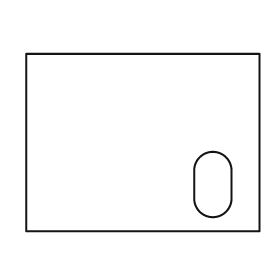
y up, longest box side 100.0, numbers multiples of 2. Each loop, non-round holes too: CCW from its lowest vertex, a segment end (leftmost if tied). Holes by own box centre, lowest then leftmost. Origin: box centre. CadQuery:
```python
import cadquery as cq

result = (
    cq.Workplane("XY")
    .moveTo(-50.0, -38.0)
    .lineTo(50.0, -38.0)
    .lineTo(50.0, 38.0)
    .lineTo(-50.0, 38.0)
    .close()
    .moveTo(22.0, -24.0)
    .threePointArc((30.0, -32.0), (38.0, -24.0))
    .lineTo(38.0, -12.0)
    .threePointArc((30.0, -4.0), (22.0, -12.0))
    .close()
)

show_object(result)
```